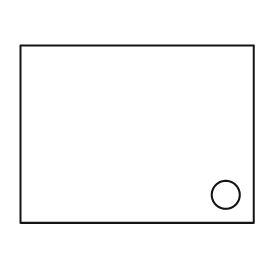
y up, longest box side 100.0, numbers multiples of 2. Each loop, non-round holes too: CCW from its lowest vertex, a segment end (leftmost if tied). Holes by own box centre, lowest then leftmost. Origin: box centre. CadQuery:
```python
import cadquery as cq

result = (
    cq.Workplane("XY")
    .moveTo(-50.0, -38.0)
    .lineTo(50.0, -38.0)
    .lineTo(50.0, 38.0)
    .lineTo(-50.0, 38.0)
    .close()
    .moveTo(38.0, -26.0)
    .circle(6.0)
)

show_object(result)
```